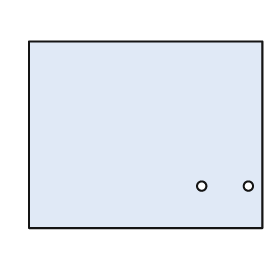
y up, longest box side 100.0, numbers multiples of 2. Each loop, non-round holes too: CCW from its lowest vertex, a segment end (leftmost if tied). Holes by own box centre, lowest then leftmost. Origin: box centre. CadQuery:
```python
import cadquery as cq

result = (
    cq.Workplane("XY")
    .moveTo(-50.0, -40.0)
    .lineTo(50.0, -40.0)
    .lineTo(50.0, 40.0)
    .lineTo(-50.0, 40.0)
    .close()
    .moveTo(24.0, -22.0)
    .circle(2.0)
    .moveTo(44.0, -22.0)
    .circle(2.0)
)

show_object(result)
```